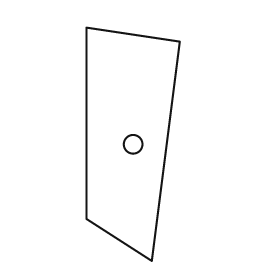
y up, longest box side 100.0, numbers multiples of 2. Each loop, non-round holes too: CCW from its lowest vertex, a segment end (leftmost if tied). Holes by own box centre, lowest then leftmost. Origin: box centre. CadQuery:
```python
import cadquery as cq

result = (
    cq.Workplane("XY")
    .moveTo(8.0, -50.0)
    .lineTo(20.0, 44.0)
    .lineTo(-20.0, 50.0)
    .lineTo(-20.0, -32.0)
    .close()
    .moveTo(0.0, 0.0)
    .circle(4.0)
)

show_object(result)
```